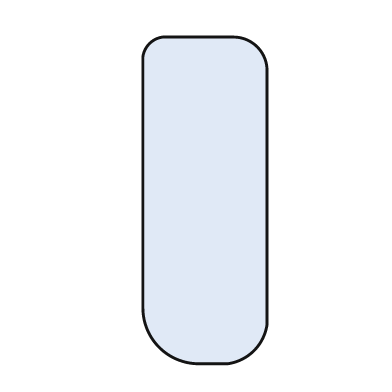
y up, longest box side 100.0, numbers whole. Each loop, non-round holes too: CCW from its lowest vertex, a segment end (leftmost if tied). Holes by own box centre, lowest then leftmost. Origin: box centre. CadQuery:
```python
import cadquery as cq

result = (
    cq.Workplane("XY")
    .moveTo(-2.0, -50.0)
    .lineTo(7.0, -50.0)
    .threePointArc((15.0, -46.0), (19.0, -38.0))
    .lineTo(19.0, 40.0)
    .threePointArc((16.0, 47.0), (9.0, 50.0))
    .lineTo(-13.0, 50.0)
    .threePointArc((-17.0, 48.0), (-19.0, 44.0))
    .lineTo(-19.0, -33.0)
    .threePointArc((-14.0, -45.0), (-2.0, -50.0))
    .close()
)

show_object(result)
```